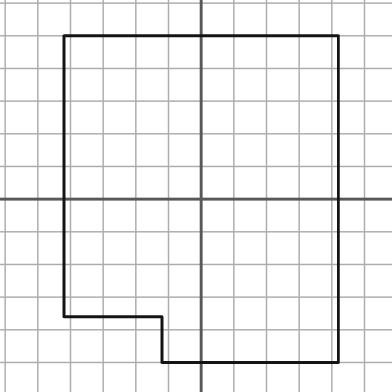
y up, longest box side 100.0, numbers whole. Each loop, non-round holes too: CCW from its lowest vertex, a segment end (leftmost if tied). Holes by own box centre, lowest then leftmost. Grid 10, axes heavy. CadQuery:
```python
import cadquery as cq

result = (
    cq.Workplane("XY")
    .moveTo(-12.0, -50.0)
    .lineTo(42.0, -50.0)
    .lineTo(42.0, 50.0)
    .lineTo(-42.0, 50.0)
    .lineTo(-42.0, -36.0)
    .lineTo(-12.0, -36.0)
    .close()
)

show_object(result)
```